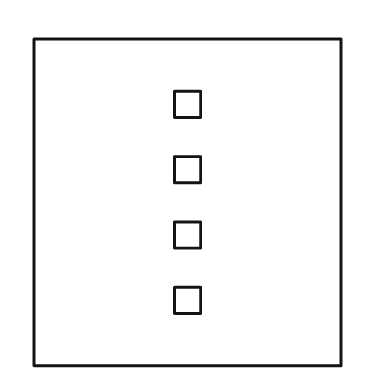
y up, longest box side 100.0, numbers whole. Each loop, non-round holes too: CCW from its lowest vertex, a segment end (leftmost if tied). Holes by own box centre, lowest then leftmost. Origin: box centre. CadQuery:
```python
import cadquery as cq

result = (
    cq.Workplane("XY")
    .moveTo(-47.0, -50.0)
    .lineTo(47.0, -50.0)
    .lineTo(47.0, 50.0)
    .lineTo(-47.0, 50.0)
    .close()
    .moveTo(-4.0, -34.0)
    .lineTo(4.0, -34.0)
    .lineTo(4.0, -26.0)
    .lineTo(-4.0, -26.0)
    .close()
    .moveTo(-4.0, -14.0)
    .lineTo(4.0, -14.0)
    .lineTo(4.0, -6.0)
    .lineTo(-4.0, -6.0)
    .close()
    .moveTo(-4.0, 6.0)
    .lineTo(4.0, 6.0)
    .lineTo(4.0, 14.0)
    .lineTo(-4.0, 14.0)
    .close()
    .moveTo(-4.0, 26.0)
    .lineTo(4.0, 26.0)
    .lineTo(4.0, 34.0)
    .lineTo(-4.0, 34.0)
    .close()
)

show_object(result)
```